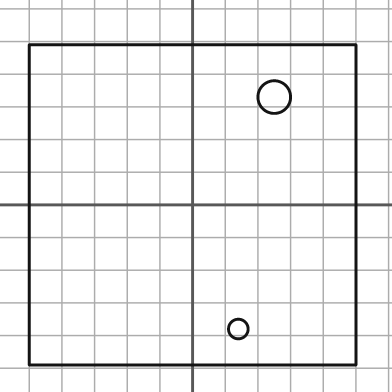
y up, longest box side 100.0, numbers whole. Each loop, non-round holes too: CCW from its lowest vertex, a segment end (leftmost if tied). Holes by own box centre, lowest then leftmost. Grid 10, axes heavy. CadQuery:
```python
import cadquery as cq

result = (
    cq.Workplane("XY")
    .moveTo(-50.0, -49.0)
    .lineTo(50.0, -49.0)
    .lineTo(50.0, 49.0)
    .lineTo(-50.0, 49.0)
    .close()
    .moveTo(14.0, -38.0)
    .circle(3.0)
    .moveTo(25.0, 33.0)
    .circle(5.0)
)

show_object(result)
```